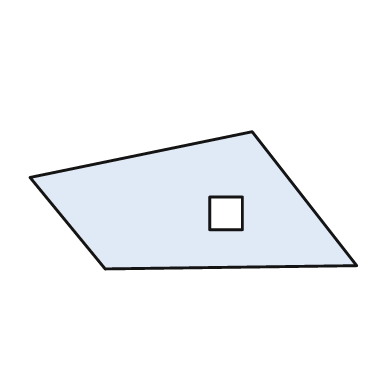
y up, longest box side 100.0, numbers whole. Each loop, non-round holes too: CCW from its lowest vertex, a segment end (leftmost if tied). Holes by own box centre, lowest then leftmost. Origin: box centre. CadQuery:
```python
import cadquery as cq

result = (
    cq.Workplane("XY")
    .moveTo(-27.0, -21.0)
    .lineTo(50.0, -20.0)
    .lineTo(18.0, 21.0)
    .lineTo(-50.0, 7.0)
    .close()
    .moveTo(5.0, -9.0)
    .lineTo(15.0, -9.0)
    .lineTo(15.0, 1.0)
    .lineTo(5.0, 1.0)
    .close()
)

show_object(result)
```